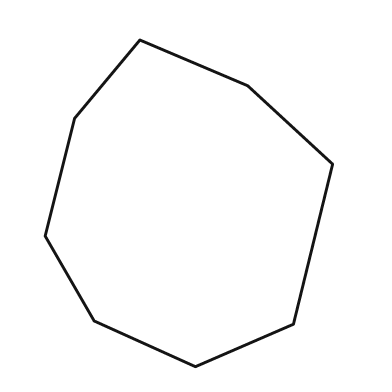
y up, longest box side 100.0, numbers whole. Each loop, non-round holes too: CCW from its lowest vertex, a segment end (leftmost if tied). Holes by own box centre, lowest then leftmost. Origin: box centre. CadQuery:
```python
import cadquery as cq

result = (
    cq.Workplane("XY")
    .moveTo(2.0, -50.0)
    .lineTo(32.0, -37.0)
    .lineTo(44.0, 12.0)
    .lineTo(18.0, 36.0)
    .lineTo(-15.0, 50.0)
    .lineTo(-35.0, 26.0)
    .lineTo(-44.0, -10.0)
    .lineTo(-29.0, -36.0)
    .close()
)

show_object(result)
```